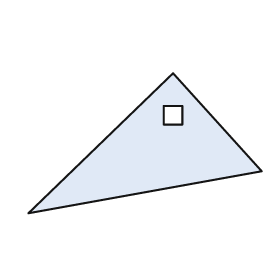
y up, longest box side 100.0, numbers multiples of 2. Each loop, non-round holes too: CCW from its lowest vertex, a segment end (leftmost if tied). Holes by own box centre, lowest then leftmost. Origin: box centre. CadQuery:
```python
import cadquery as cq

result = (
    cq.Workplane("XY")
    .moveTo(-50.0, -30.0)
    .lineTo(50.0, -12.0)
    .lineTo(12.0, 30.0)
    .close()
    .moveTo(8.0, 8.0)
    .lineTo(16.0, 8.0)
    .lineTo(16.0, 16.0)
    .lineTo(8.0, 16.0)
    .close()
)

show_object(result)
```